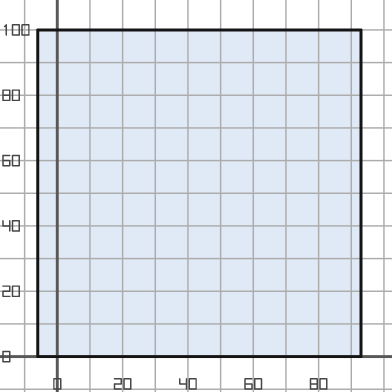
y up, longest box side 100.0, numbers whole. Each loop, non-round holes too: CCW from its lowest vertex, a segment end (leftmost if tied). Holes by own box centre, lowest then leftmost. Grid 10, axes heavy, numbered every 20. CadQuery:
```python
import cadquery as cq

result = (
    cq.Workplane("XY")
    .moveTo(-6.0, 0.0)
    .lineTo(93.0, 0.0)
    .lineTo(93.0, 100.0)
    .lineTo(-6.0, 100.0)
    .close()
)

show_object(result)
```